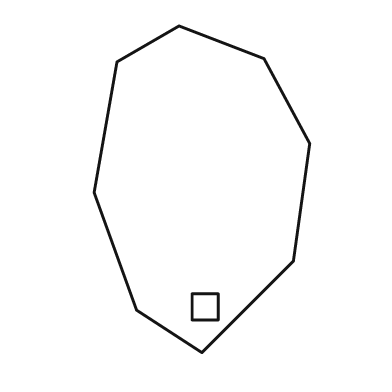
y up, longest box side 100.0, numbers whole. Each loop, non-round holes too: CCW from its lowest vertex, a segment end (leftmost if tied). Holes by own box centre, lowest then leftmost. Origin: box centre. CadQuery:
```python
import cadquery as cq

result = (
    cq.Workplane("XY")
    .moveTo(0.0, -50.0)
    .lineTo(28.0, -22.0)
    .lineTo(33.0, 14.0)
    .lineTo(19.0, 40.0)
    .lineTo(-7.0, 50.0)
    .lineTo(-26.0, 39.0)
    .lineTo(-33.0, -1.0)
    .lineTo(-20.0, -37.0)
    .close()
    .moveTo(-3.0, -40.0)
    .lineTo(5.0, -40.0)
    .lineTo(5.0, -32.0)
    .lineTo(-3.0, -32.0)
    .close()
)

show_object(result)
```